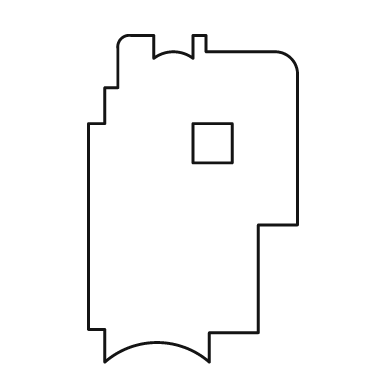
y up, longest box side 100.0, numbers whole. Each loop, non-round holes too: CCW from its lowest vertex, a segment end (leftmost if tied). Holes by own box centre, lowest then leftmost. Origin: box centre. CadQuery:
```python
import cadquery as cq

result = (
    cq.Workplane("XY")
    .moveTo(-27.0, -50.0)
    .threePointArc((-11.0, -44.0), (5.0, -50.0))
    .lineTo(5.0, -41.0)
    .lineTo(20.0, -41.0)
    .lineTo(20.0, -8.0)
    .lineTo(32.0, -8.0)
    .lineTo(32.0, 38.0)
    .threePointArc((30.0, 43.0), (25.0, 45.0))
    .lineTo(4.0, 45.0)
    .lineTo(4.0, 50.0)
    .lineTo(0.0, 50.0)
    .lineTo(0.0, 43.0)
    .threePointArc((-6.0, 45.0), (-12.0, 43.0))
    .lineTo(-12.0, 50.0)
    .lineTo(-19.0, 50.0)
    .threePointArc((-22.0, 49.0), (-23.0, 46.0))
    .lineTo(-23.0, 34.0)
    .lineTo(-27.0, 34.0)
    .lineTo(-27.0, 23.0)
    .lineTo(-32.0, 23.0)
    .lineTo(-32.0, -40.0)
    .lineTo(-27.0, -40.0)
    .close()
    .moveTo(0.0, 11.0)
    .lineTo(12.0, 11.0)
    .lineTo(12.0, 23.0)
    .lineTo(0.0, 23.0)
    .close()
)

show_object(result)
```